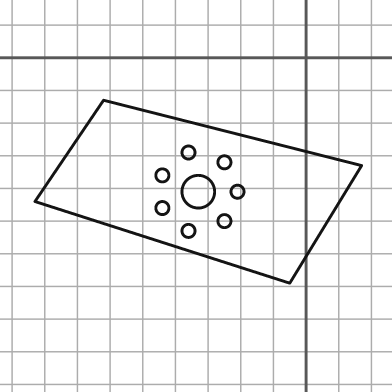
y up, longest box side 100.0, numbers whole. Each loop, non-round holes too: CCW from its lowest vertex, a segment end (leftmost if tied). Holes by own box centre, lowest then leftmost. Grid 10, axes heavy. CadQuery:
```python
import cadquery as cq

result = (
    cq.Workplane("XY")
    .moveTo(-5.0, -69.0)
    .lineTo(17.0, -33.0)
    .lineTo(-62.0, -13.0)
    .lineTo(-83.0, -44.0)
    .close()
    .moveTo(-36.0, -53.0)
    .circle(2.0)
    .moveTo(-25.0, -50.0)
    .circle(2.0)
    .moveTo(-44.0, -46.0)
    .circle(2.0)
    .moveTo(-33.0, -41.0)
    .circle(5.0)
    .moveTo(-21.0, -41.0)
    .circle(2.0)
    .moveTo(-44.0, -36.0)
    .circle(2.0)
    .moveTo(-25.0, -32.0)
    .circle(2.0)
    .moveTo(-36.0, -29.0)
    .circle(2.0)
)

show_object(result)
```